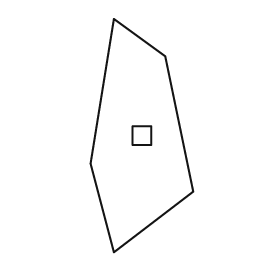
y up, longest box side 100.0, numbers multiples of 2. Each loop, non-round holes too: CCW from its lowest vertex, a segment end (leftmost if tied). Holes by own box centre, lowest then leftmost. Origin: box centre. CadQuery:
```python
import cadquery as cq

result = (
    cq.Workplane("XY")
    .moveTo(-12.0, -50.0)
    .lineTo(22.0, -24.0)
    .lineTo(10.0, 34.0)
    .lineTo(-12.0, 50.0)
    .lineTo(-22.0, -12.0)
    .close()
    .moveTo(-4.0, -4.0)
    .lineTo(4.0, -4.0)
    .lineTo(4.0, 4.0)
    .lineTo(-4.0, 4.0)
    .close()
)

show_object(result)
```